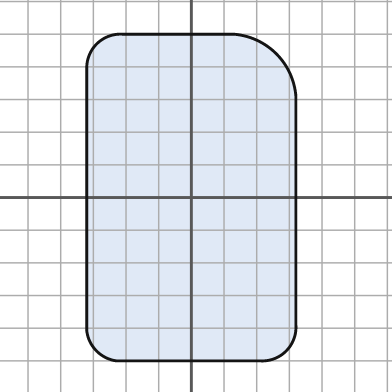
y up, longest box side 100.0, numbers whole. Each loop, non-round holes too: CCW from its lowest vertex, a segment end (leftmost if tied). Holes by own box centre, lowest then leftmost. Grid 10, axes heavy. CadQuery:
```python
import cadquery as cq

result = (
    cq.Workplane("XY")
    .moveTo(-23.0, -50.0)
    .lineTo(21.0, -50.0)
    .threePointArc((29.0, -47.0), (32.0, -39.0))
    .lineTo(32.0, 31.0)
    .threePointArc((26.0, 44.0), (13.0, 50.0))
    .lineTo(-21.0, 50.0)
    .threePointArc((-29.0, 47.0), (-32.0, 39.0))
    .lineTo(-32.0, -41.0)
    .threePointArc((-29.0, -47.0), (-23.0, -50.0))
    .close()
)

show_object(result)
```